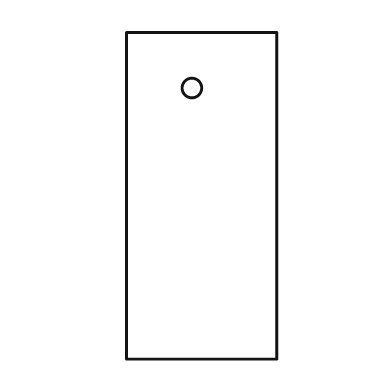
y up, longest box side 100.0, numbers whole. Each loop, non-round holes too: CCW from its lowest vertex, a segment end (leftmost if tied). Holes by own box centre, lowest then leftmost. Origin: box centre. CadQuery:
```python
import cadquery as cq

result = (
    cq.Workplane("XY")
    .moveTo(-23.0, -50.0)
    .lineTo(23.0, -50.0)
    .lineTo(23.0, 50.0)
    .lineTo(-23.0, 50.0)
    .close()
    .moveTo(-3.0, 33.0)
    .circle(3.0)
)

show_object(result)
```